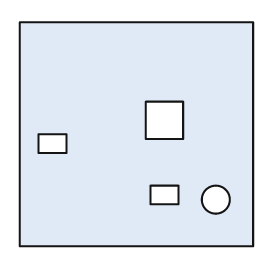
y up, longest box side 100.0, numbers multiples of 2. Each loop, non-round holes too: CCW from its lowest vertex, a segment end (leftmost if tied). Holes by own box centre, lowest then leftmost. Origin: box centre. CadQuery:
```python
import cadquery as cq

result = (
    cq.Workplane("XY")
    .moveTo(-50.0, -48.0)
    .lineTo(50.0, -48.0)
    .lineTo(50.0, 48.0)
    .lineTo(-50.0, 48.0)
    .close()
    .moveTo(34.0, -28.0)
    .circle(6.0)
    .moveTo(6.0, -30.0)
    .lineTo(18.0, -30.0)
    .lineTo(18.0, -22.0)
    .lineTo(6.0, -22.0)
    .close()
    .moveTo(-42.0, -8.0)
    .lineTo(-30.0, -8.0)
    .lineTo(-30.0, 0.0)
    .lineTo(-42.0, 0.0)
    .close()
    .moveTo(4.0, -2.0)
    .lineTo(20.0, -2.0)
    .lineTo(20.0, 14.0)
    .lineTo(4.0, 14.0)
    .close()
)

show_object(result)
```